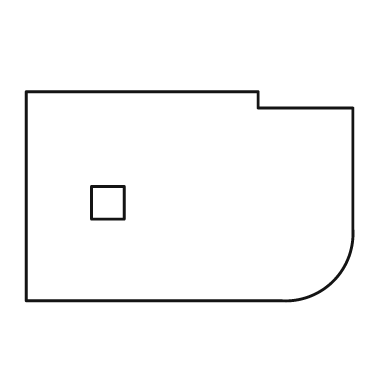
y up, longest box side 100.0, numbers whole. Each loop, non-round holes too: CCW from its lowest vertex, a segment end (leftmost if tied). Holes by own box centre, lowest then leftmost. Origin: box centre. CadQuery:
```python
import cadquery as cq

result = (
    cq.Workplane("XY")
    .moveTo(-50.0, -32.0)
    .lineTo(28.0, -32.0)
    .threePointArc((44.0, -26.0), (50.0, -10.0))
    .lineTo(50.0, 27.0)
    .lineTo(21.0, 27.0)
    .lineTo(21.0, 32.0)
    .lineTo(-50.0, 32.0)
    .close()
    .moveTo(-30.0, -7.0)
    .lineTo(-20.0, -7.0)
    .lineTo(-20.0, 3.0)
    .lineTo(-30.0, 3.0)
    .close()
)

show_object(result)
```